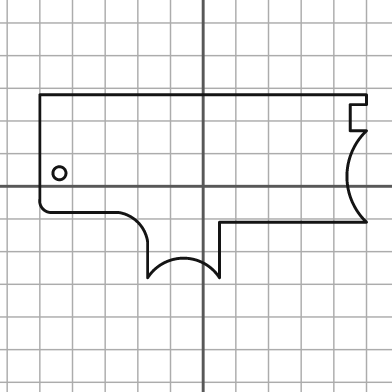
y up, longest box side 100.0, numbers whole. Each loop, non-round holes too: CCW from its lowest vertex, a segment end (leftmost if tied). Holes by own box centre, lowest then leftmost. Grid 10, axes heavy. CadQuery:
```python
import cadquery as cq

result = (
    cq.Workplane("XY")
    .moveTo(-17.0, -28.0)
    .threePointArc((-6.0, -22.0), (5.0, -28.0))
    .lineTo(5.0, -11.0)
    .lineTo(50.0, -11.0)
    .threePointArc((44.0, 3.0), (50.0, 17.0))
    .lineTo(45.0, 17.0)
    .lineTo(45.0, 25.0)
    .lineTo(50.0, 25.0)
    .lineTo(50.0, 28.0)
    .lineTo(-50.0, 28.0)
    .lineTo(-50.0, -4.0)
    .threePointArc((-49.0, -7.0), (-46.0, -8.0))
    .lineTo(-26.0, -8.0)
    .threePointArc((-20.0, -11.0), (-17.0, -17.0))
    .close()
    .moveTo(-44.0, 4.0)
    .circle(2.0)
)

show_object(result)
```